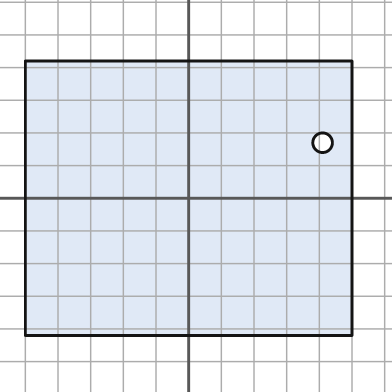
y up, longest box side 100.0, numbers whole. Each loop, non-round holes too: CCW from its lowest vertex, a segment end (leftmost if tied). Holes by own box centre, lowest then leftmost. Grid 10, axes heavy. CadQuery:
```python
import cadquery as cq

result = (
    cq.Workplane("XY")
    .moveTo(-50.0, -42.0)
    .lineTo(50.0, -42.0)
    .lineTo(50.0, 42.0)
    .lineTo(-50.0, 42.0)
    .close()
    .moveTo(41.0, 17.0)
    .circle(3.0)
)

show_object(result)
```